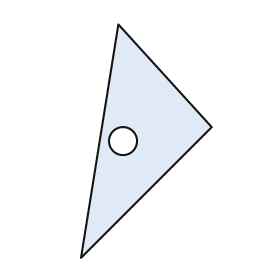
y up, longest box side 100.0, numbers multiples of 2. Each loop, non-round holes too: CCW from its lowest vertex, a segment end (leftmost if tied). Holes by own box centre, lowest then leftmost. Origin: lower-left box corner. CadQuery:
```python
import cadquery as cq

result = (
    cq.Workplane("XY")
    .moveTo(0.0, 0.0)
    .lineTo(56.0, 56.0)
    .lineTo(16.0, 100.0)
    .close()
    .moveTo(18.0, 50.0)
    .circle(6.0)
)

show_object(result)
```